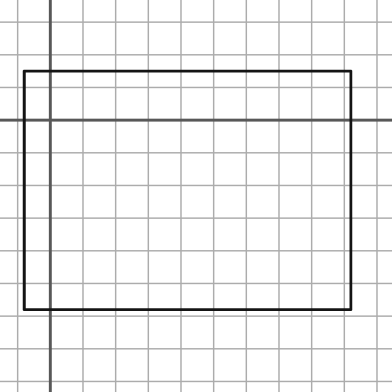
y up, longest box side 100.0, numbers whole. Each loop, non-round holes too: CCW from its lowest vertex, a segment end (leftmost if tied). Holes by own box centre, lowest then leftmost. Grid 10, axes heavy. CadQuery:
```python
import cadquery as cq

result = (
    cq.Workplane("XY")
    .moveTo(-8.0, -58.0)
    .lineTo(92.0, -58.0)
    .lineTo(92.0, 15.0)
    .lineTo(-8.0, 15.0)
    .close()
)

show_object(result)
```